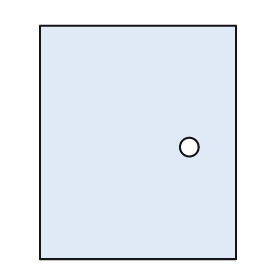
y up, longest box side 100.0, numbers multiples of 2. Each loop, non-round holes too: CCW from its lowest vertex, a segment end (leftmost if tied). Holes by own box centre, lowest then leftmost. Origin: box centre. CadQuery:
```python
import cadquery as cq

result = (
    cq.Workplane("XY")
    .moveTo(-42.0, -50.0)
    .lineTo(42.0, -50.0)
    .lineTo(42.0, 50.0)
    .lineTo(-42.0, 50.0)
    .close()
    .moveTo(22.0, -2.0)
    .circle(4.0)
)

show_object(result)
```